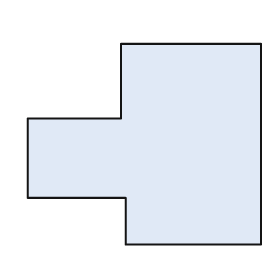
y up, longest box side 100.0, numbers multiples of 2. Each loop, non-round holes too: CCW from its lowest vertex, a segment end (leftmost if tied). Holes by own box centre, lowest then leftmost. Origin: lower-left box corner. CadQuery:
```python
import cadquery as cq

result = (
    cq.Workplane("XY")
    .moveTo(42.0, 0.0)
    .lineTo(100.0, 0.0)
    .lineTo(100.0, 86.0)
    .lineTo(40.0, 86.0)
    .lineTo(40.0, 54.0)
    .lineTo(0.0, 54.0)
    .lineTo(0.0, 20.0)
    .lineTo(42.0, 20.0)
    .close()
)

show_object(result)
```